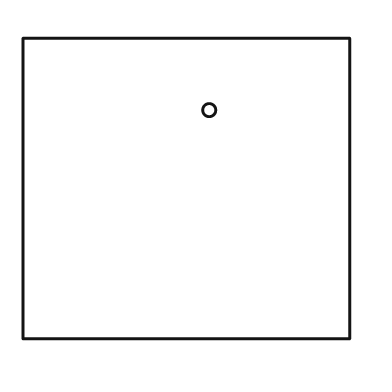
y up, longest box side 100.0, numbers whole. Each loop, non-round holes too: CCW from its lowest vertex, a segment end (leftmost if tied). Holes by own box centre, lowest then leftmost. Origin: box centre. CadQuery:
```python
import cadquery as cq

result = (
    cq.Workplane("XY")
    .moveTo(-50.0, -46.0)
    .lineTo(50.0, -46.0)
    .lineTo(50.0, 46.0)
    .lineTo(-50.0, 46.0)
    .close()
    .moveTo(7.0, 24.0)
    .circle(2.0)
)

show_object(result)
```